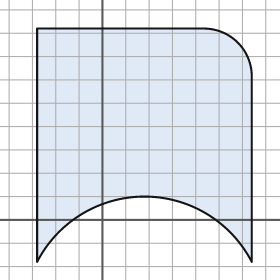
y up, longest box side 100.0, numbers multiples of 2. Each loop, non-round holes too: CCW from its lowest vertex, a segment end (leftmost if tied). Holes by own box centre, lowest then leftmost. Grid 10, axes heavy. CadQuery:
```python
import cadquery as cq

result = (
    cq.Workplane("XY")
    .moveTo(-28.0, -18.0)
    .threePointArc((18.0, 10.0), (64.0, -18.0))
    .lineTo(64.0, 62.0)
    .threePointArc((58.0, 76.0), (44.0, 82.0))
    .lineTo(-28.0, 82.0)
    .close()
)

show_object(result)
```